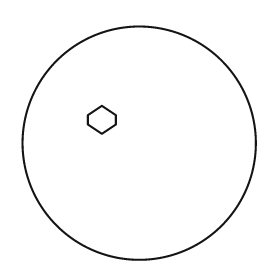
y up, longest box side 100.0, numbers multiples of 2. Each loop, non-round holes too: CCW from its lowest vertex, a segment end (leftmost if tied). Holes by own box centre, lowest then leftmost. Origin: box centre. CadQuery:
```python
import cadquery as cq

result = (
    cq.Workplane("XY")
    .moveTo(0.0, 0.0)
    .circle(50.0)
    .moveTo(-16.0, 4.0)
    .lineTo(-10.0, 8.0)
    .lineTo(-10.0, 12.0)
    .lineTo(-16.0, 16.0)
    .lineTo(-22.0, 12.0)
    .lineTo(-22.0, 8.0)
    .close()
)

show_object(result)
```